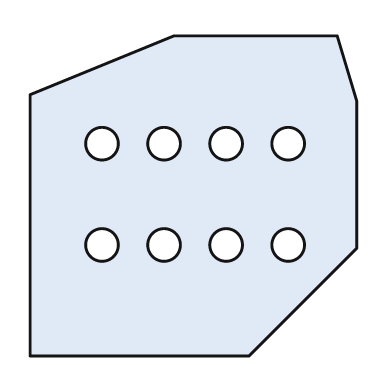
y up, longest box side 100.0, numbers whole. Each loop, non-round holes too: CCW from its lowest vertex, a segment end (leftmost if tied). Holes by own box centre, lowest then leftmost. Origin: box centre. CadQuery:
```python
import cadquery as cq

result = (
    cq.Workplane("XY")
    .moveTo(-50.0, -49.0)
    .lineTo(17.0, -49.0)
    .lineTo(50.0, -16.0)
    .lineTo(50.0, 29.0)
    .lineTo(44.0, 49.0)
    .lineTo(-6.0, 49.0)
    .lineTo(-50.0, 31.0)
    .close()
    .moveTo(-28.0, -15.0)
    .circle(5.0)
    .moveTo(-9.0, -15.0)
    .circle(5.0)
    .moveTo(10.0, -15.0)
    .circle(5.0)
    .moveTo(29.0, -15.0)
    .circle(5.0)
    .moveTo(-28.0, 16.0)
    .circle(5.0)
    .moveTo(-9.0, 16.0)
    .circle(5.0)
    .moveTo(10.0, 16.0)
    .circle(5.0)
    .moveTo(29.0, 16.0)
    .circle(5.0)
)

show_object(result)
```